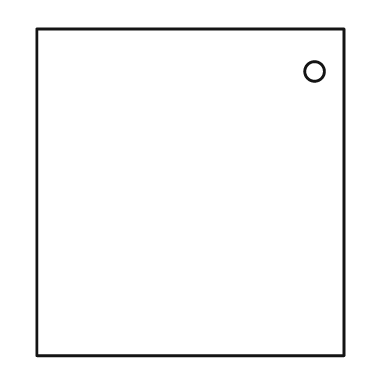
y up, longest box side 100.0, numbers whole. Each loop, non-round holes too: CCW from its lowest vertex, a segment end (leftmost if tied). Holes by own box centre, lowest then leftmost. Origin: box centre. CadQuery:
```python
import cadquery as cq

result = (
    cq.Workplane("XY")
    .moveTo(-47.0, -50.0)
    .lineTo(47.0, -50.0)
    .lineTo(47.0, 50.0)
    .lineTo(-47.0, 50.0)
    .close()
    .moveTo(38.0, 37.0)
    .circle(3.0)
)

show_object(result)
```